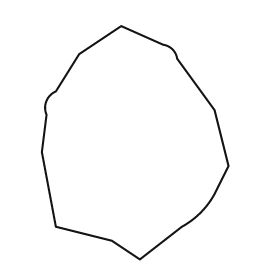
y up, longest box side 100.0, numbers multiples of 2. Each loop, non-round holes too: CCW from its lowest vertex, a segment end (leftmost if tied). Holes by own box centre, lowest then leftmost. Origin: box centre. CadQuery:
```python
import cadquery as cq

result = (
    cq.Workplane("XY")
    .moveTo(2.0, -50.0)
    .lineTo(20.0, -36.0)
    .threePointArc((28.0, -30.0), (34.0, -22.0))
    .lineTo(40.0, -10.0)
    .lineTo(34.0, 14.0)
    .lineTo(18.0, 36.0)
    .threePointArc((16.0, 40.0), (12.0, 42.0))
    .lineTo(-6.0, 50.0)
    .lineTo(-24.0, 38.0)
    .lineTo(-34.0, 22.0)
    .threePointArc((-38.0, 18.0), (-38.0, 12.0))
    .lineTo(-40.0, -4.0)
    .lineTo(-34.0, -36.0)
    .lineTo(-10.0, -42.0)
    .close()
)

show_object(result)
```